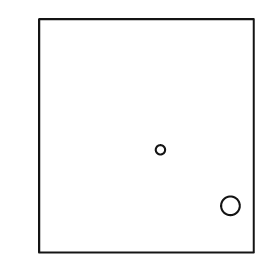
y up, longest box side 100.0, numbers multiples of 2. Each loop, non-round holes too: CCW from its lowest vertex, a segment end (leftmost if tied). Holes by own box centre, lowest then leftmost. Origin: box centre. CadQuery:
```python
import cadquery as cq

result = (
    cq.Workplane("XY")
    .moveTo(-46.0, -50.0)
    .lineTo(46.0, -50.0)
    .lineTo(46.0, 50.0)
    .lineTo(-46.0, 50.0)
    .close()
    .moveTo(36.0, -30.0)
    .circle(4.0)
    .moveTo(6.0, -6.0)
    .circle(2.0)
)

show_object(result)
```